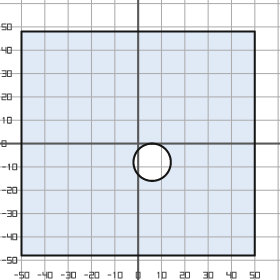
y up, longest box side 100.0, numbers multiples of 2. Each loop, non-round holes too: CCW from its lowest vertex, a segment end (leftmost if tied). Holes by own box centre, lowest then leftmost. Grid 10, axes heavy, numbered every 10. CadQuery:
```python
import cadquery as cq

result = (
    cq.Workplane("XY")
    .moveTo(-50.0, -48.0)
    .lineTo(50.0, -48.0)
    .lineTo(50.0, 48.0)
    .lineTo(-50.0, 48.0)
    .close()
    .moveTo(6.0, -8.0)
    .circle(8.0)
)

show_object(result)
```